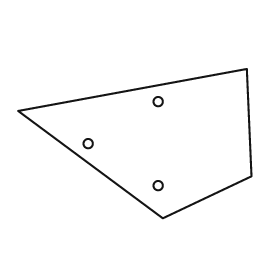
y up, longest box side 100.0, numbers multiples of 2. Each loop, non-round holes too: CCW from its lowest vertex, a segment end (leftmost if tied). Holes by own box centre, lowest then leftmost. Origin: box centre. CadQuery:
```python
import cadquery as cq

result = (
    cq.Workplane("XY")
    .moveTo(12.0, -32.0)
    .lineTo(50.0, -14.0)
    .lineTo(48.0, 32.0)
    .lineTo(-50.0, 14.0)
    .close()
    .moveTo(10.0, -18.0)
    .circle(2.0)
    .moveTo(-20.0, 0.0)
    .circle(2.0)
    .moveTo(10.0, 18.0)
    .circle(2.0)
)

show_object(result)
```